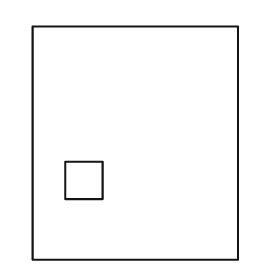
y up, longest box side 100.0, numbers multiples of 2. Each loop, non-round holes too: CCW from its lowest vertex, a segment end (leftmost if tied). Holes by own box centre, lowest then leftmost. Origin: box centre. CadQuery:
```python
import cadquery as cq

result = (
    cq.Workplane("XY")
    .moveTo(-44.0, -50.0)
    .lineTo(44.0, -50.0)
    .lineTo(44.0, 50.0)
    .lineTo(-44.0, 50.0)
    .close()
    .moveTo(-30.0, -24.0)
    .lineTo(-14.0, -24.0)
    .lineTo(-14.0, -8.0)
    .lineTo(-30.0, -8.0)
    .close()
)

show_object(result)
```